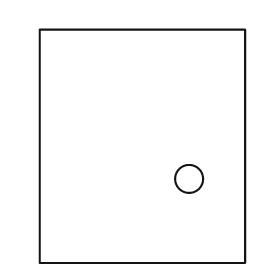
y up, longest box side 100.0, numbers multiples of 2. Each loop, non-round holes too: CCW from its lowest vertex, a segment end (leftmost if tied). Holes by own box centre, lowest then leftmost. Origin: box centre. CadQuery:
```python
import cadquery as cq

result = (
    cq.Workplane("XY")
    .moveTo(-44.0, -50.0)
    .lineTo(44.0, -50.0)
    .lineTo(44.0, 50.0)
    .lineTo(-44.0, 50.0)
    .close()
    .moveTo(20.0, -14.0)
    .circle(6.0)
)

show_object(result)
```